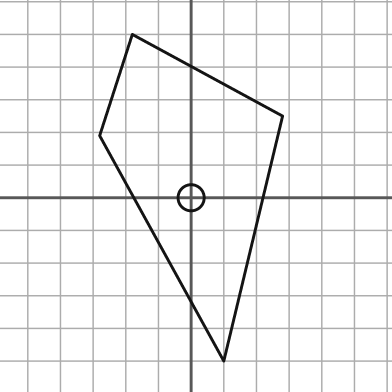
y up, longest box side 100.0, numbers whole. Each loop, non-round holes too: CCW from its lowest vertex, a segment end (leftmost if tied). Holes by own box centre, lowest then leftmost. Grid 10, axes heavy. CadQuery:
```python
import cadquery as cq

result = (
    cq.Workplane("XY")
    .moveTo(10.0, -50.0)
    .lineTo(28.0, 25.0)
    .lineTo(-18.0, 50.0)
    .lineTo(-28.0, 19.0)
    .close()
    .moveTo(0.0, 0.0)
    .circle(4.0)
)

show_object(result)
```